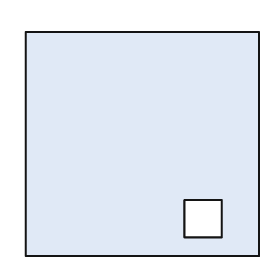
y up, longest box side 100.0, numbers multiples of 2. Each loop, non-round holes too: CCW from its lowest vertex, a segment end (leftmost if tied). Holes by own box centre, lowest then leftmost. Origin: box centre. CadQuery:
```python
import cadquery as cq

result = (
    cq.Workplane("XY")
    .moveTo(-50.0, -48.0)
    .lineTo(50.0, -48.0)
    .lineTo(50.0, 48.0)
    .lineTo(-50.0, 48.0)
    .close()
    .moveTo(18.0, -40.0)
    .lineTo(34.0, -40.0)
    .lineTo(34.0, -24.0)
    .lineTo(18.0, -24.0)
    .close()
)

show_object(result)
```